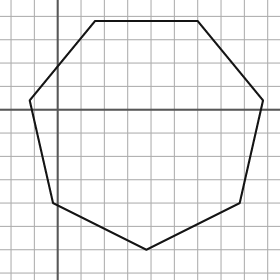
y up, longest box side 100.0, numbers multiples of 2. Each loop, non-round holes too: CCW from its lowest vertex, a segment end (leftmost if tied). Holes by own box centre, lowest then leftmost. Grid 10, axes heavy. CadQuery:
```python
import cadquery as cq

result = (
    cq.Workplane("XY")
    .moveTo(38.0, -60.0)
    .lineTo(78.0, -40.0)
    .lineTo(88.0, 4.0)
    .lineTo(60.0, 38.0)
    .lineTo(16.0, 38.0)
    .lineTo(-12.0, 4.0)
    .lineTo(-2.0, -40.0)
    .close()
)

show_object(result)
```